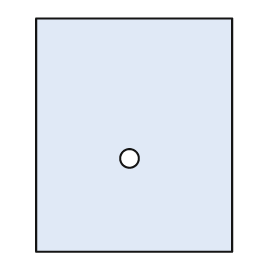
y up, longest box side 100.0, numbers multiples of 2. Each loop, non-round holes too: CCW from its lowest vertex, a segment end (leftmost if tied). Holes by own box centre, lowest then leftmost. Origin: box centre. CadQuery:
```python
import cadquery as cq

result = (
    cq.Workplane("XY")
    .moveTo(-42.0, -50.0)
    .lineTo(42.0, -50.0)
    .lineTo(42.0, 50.0)
    .lineTo(-42.0, 50.0)
    .close()
    .moveTo(-2.0, -10.0)
    .circle(4.0)
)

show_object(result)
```